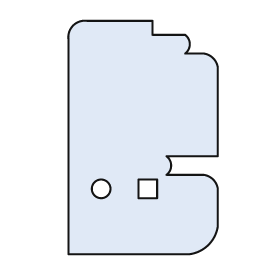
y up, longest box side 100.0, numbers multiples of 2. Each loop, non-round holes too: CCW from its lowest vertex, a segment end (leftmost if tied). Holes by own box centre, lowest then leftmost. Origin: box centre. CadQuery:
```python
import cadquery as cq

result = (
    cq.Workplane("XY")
    .moveTo(-32.0, -50.0)
    .lineTo(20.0, -50.0)
    .threePointArc((28.0, -46.0), (32.0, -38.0))
    .lineTo(32.0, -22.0)
    .threePointArc((30.0, -18.0), (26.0, -16.0))
    .lineTo(10.0, -16.0)
    .threePointArc((12.0, -12.0), (10.0, -8.0))
    .lineTo(32.0, -8.0)
    .lineTo(32.0, 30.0)
    .threePointArc((30.0, 34.0), (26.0, 36.0))
    .lineTo(18.0, 36.0)
    .threePointArc((20.0, 40.0), (18.0, 44.0))
    .lineTo(4.0, 44.0)
    .lineTo(4.0, 50.0)
    .lineTo(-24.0, 50.0)
    .threePointArc((-30.0, 48.0), (-32.0, 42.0))
    .close()
    .moveTo(-18.0, -22.0)
    .circle(4.0)
    .moveTo(-2.0, -26.0)
    .lineTo(6.0, -26.0)
    .lineTo(6.0, -18.0)
    .lineTo(-2.0, -18.0)
    .close()
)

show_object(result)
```